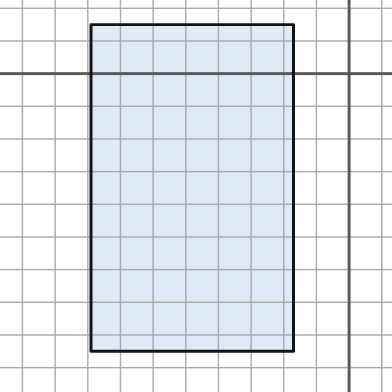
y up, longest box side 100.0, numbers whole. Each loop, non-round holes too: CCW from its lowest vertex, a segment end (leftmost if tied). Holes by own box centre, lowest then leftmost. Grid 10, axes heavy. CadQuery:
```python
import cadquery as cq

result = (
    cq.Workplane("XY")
    .moveTo(-79.0, -85.0)
    .lineTo(-17.0, -85.0)
    .lineTo(-17.0, 15.0)
    .lineTo(-79.0, 15.0)
    .close()
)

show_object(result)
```